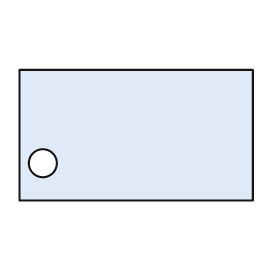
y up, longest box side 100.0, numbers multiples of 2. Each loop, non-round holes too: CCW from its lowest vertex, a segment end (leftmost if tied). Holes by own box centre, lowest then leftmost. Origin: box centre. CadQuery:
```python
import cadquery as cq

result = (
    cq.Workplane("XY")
    .moveTo(-50.0, -28.0)
    .lineTo(50.0, -28.0)
    .lineTo(50.0, 28.0)
    .lineTo(-50.0, 28.0)
    .close()
    .moveTo(-40.0, -12.0)
    .circle(6.0)
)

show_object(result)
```